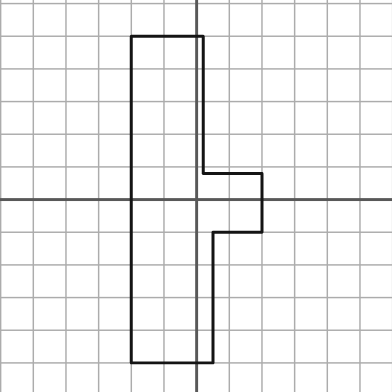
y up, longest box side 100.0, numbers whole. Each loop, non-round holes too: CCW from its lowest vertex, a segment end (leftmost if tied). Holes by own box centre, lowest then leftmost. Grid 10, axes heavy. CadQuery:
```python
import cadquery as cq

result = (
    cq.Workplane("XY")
    .moveTo(-20.0, -50.0)
    .lineTo(5.0, -50.0)
    .lineTo(5.0, -10.0)
    .lineTo(20.0, -10.0)
    .lineTo(20.0, 8.0)
    .lineTo(2.0, 8.0)
    .lineTo(2.0, 50.0)
    .lineTo(-20.0, 50.0)
    .close()
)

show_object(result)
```